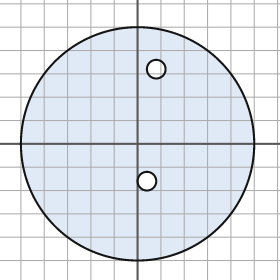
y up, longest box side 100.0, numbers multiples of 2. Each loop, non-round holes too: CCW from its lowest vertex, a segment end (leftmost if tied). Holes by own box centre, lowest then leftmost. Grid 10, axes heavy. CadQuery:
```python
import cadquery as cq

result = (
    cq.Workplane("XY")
    .moveTo(0.0, 0.0)
    .circle(50.0)
    .moveTo(4.0, -16.0)
    .circle(4.0)
    .moveTo(8.0, 32.0)
    .circle(4.0)
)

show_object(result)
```